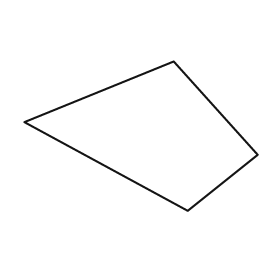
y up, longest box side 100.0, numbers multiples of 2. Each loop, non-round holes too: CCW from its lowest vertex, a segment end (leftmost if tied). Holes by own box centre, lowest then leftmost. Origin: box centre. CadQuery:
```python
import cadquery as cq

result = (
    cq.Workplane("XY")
    .moveTo(20.0, -32.0)
    .lineTo(50.0, -8.0)
    .lineTo(14.0, 32.0)
    .lineTo(-50.0, 6.0)
    .close()
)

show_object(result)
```